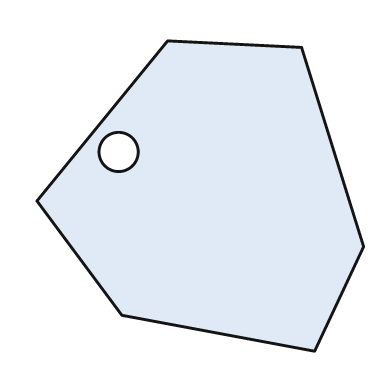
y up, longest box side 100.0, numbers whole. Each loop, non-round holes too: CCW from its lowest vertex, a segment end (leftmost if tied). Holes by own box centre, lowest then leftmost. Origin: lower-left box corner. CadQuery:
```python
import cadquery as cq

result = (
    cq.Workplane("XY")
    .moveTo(85.0, 0.0)
    .lineTo(100.0, 32.0)
    .lineTo(81.0, 93.0)
    .lineTo(40.0, 95.0)
    .lineTo(0.0, 46.0)
    .lineTo(26.0, 11.0)
    .close()
    .moveTo(25.0, 61.0)
    .circle(6.0)
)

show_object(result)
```